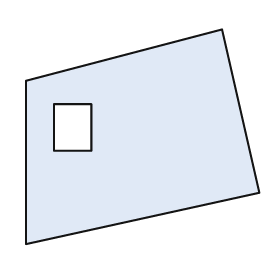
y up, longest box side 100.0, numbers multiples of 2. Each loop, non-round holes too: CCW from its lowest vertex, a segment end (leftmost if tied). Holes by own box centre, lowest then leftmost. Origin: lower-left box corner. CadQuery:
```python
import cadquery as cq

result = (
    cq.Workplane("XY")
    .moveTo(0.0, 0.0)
    .lineTo(100.0, 22.0)
    .lineTo(84.0, 92.0)
    .lineTo(0.0, 70.0)
    .close()
    .moveTo(12.0, 40.0)
    .lineTo(28.0, 40.0)
    .lineTo(28.0, 60.0)
    .lineTo(12.0, 60.0)
    .close()
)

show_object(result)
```